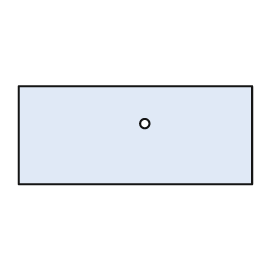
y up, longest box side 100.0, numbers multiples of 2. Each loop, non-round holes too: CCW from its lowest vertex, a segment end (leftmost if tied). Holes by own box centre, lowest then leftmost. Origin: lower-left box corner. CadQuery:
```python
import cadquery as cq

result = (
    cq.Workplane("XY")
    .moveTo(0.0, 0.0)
    .lineTo(100.0, 0.0)
    .lineTo(100.0, 42.0)
    .lineTo(0.0, 42.0)
    .close()
    .moveTo(54.0, 26.0)
    .circle(2.0)
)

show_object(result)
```